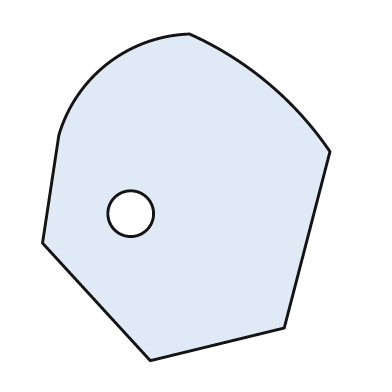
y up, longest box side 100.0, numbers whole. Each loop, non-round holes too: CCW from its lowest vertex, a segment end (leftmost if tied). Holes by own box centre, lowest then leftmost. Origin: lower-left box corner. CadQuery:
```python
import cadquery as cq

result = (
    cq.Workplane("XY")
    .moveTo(33.0, 0.0)
    .lineTo(74.0, 10.0)
    .lineTo(88.0, 64.0)
    .threePointArc((69.0, 85.0), (45.0, 100.0))
    .threePointArc((20.0, 91.0), (5.0, 69.0))
    .lineTo(0.0, 36.0)
    .close()
    .moveTo(27.0, 45.0)
    .circle(7.0)
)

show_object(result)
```